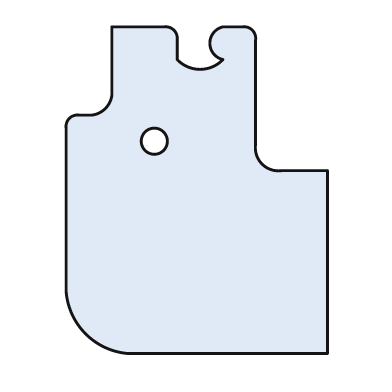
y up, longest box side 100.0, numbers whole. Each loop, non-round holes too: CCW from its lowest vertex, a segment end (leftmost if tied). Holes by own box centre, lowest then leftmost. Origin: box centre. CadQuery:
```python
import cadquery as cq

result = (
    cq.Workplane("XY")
    .moveTo(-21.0, -50.0)
    .lineTo(40.0, -50.0)
    .lineTo(40.0, 6.0)
    .lineTo(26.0, 6.0)
    .threePointArc((20.0, 8.0), (18.0, 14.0))
    .lineTo(18.0, 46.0)
    .threePointArc((17.0, 49.0), (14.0, 50.0))
    .lineTo(8.0, 50.0)
    .threePointArc((4.0, 45.0), (8.0, 40.0))
    .threePointArc((1.0, 37.0), (-6.0, 40.0))
    .lineTo(-6.0, 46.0)
    .threePointArc((-7.0, 49.0), (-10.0, 50.0))
    .lineTo(-26.0, 50.0)
    .lineTo(-26.0, 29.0)
    .threePointArc((-28.0, 25.0), (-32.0, 23.0))
    .lineTo(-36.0, 23.0)
    .threePointArc((-39.0, 22.0), (-40.0, 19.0))
    .lineTo(-40.0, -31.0)
    .threePointArc((-34.0, -44.0), (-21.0, -50.0))
    .close()
    .moveTo(-13.0, 15.0)
    .circle(4.0)
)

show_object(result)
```